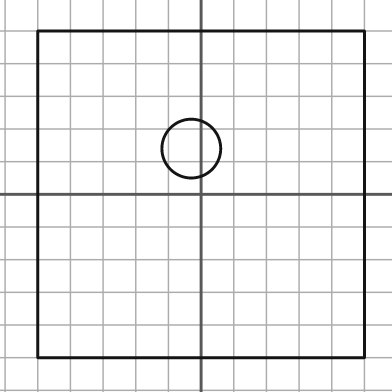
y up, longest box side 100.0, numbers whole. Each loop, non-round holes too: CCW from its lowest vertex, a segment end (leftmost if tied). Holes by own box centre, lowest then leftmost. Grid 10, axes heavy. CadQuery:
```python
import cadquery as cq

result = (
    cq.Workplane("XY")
    .moveTo(-50.0, -50.0)
    .lineTo(50.0, -50.0)
    .lineTo(50.0, 50.0)
    .lineTo(-50.0, 50.0)
    .close()
    .moveTo(-3.0, 14.0)
    .circle(9.0)
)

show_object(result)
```